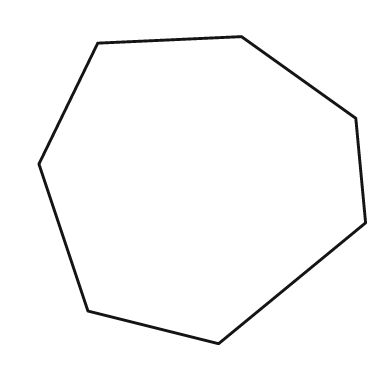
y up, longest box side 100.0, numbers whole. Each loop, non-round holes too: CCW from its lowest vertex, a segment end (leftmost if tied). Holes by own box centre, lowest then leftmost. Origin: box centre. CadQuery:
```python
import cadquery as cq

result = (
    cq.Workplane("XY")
    .moveTo(5.0, -47.0)
    .lineTo(50.0, -10.0)
    .lineTo(47.0, 22.0)
    .lineTo(12.0, 47.0)
    .lineTo(-32.0, 45.0)
    .lineTo(-50.0, 8.0)
    .lineTo(-35.0, -37.0)
    .close()
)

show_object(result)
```